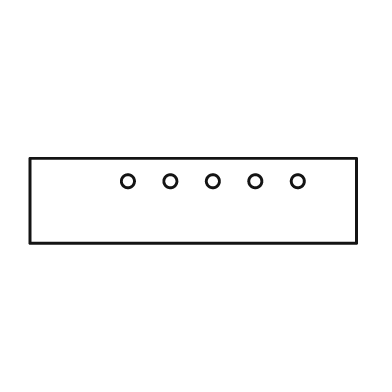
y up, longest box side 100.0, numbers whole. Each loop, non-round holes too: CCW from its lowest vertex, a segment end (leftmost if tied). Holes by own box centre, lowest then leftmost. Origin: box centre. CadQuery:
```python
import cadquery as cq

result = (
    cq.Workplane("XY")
    .moveTo(-50.0, -13.0)
    .lineTo(50.0, -13.0)
    .lineTo(50.0, 13.0)
    .lineTo(-50.0, 13.0)
    .close()
    .moveTo(-20.0, 6.0)
    .circle(2.0)
    .moveTo(-7.0, 6.0)
    .circle(2.0)
    .moveTo(6.0, 6.0)
    .circle(2.0)
    .moveTo(19.0, 6.0)
    .circle(2.0)
    .moveTo(32.0, 6.0)
    .circle(2.0)
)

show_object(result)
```